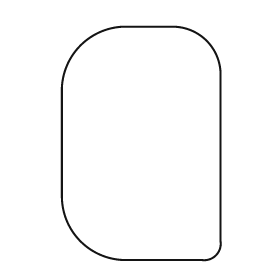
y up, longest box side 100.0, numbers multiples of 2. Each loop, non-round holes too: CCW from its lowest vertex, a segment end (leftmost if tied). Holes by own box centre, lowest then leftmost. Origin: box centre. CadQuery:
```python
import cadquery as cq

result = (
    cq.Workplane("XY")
    .moveTo(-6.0, -50.0)
    .lineTo(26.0, -50.0)
    .threePointArc((32.0, -48.0), (34.0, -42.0))
    .lineTo(34.0, 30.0)
    .threePointArc((28.0, 44.0), (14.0, 50.0))
    .lineTo(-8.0, 50.0)
    .threePointArc((-26.0, 42.0), (-34.0, 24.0))
    .lineTo(-34.0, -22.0)
    .threePointArc((-26.0, -42.0), (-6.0, -50.0))
    .close()
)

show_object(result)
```